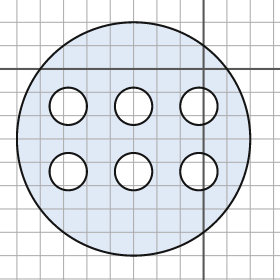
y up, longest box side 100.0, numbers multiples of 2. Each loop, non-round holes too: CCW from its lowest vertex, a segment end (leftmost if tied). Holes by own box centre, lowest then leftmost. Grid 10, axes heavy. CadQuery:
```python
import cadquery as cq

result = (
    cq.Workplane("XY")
    .moveTo(-30.0, -30.0)
    .circle(50.0)
    .moveTo(-58.0, -44.0)
    .circle(8.0)
    .moveTo(-30.0, -44.0)
    .circle(8.0)
    .moveTo(-2.0, -44.0)
    .circle(8.0)
    .moveTo(-58.0, -16.0)
    .circle(8.0)
    .moveTo(-30.0, -16.0)
    .circle(8.0)
    .moveTo(-2.0, -16.0)
    .circle(8.0)
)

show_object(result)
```